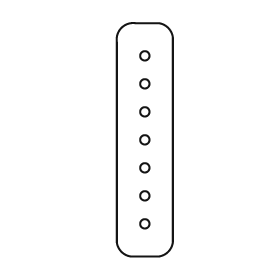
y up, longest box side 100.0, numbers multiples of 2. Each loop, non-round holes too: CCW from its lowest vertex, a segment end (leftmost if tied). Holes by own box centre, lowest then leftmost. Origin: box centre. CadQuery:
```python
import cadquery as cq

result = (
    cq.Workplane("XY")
    .moveTo(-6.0, -50.0)
    .lineTo(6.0, -50.0)
    .threePointArc((10.0, -48.0), (12.0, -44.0))
    .lineTo(12.0, 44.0)
    .threePointArc((10.0, 48.0), (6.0, 50.0))
    .lineTo(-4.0, 50.0)
    .threePointArc((-10.0, 48.0), (-12.0, 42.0))
    .lineTo(-12.0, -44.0)
    .threePointArc((-10.0, -48.0), (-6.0, -50.0))
    .close()
    .moveTo(0.0, -36.0)
    .circle(2.0)
    .moveTo(0.0, -24.0)
    .circle(2.0)
    .moveTo(0.0, -12.0)
    .circle(2.0)
    .moveTo(0.0, 0.0)
    .circle(2.0)
    .moveTo(0.0, 12.0)
    .circle(2.0)
    .moveTo(0.0, 24.0)
    .circle(2.0)
    .moveTo(0.0, 36.0)
    .circle(2.0)
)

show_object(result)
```